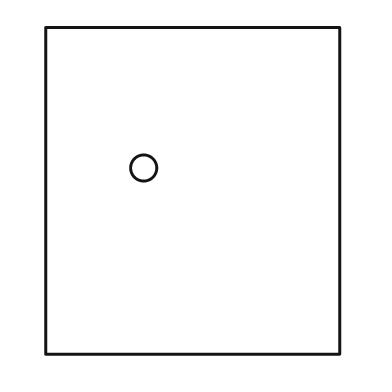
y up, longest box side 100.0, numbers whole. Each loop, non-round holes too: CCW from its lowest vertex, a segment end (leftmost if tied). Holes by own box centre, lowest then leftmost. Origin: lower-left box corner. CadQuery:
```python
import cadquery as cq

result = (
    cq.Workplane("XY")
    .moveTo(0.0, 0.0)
    .lineTo(90.0, 0.0)
    .lineTo(90.0, 100.0)
    .lineTo(0.0, 100.0)
    .close()
    .moveTo(30.0, 57.0)
    .circle(4.0)
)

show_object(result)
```